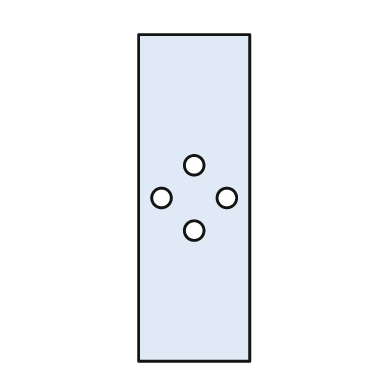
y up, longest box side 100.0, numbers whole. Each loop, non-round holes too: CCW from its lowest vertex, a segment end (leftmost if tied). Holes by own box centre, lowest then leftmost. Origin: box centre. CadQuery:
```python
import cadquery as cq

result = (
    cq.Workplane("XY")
    .moveTo(-17.0, -50.0)
    .lineTo(17.0, -50.0)
    .lineTo(17.0, 50.0)
    .lineTo(-17.0, 50.0)
    .close()
    .moveTo(0.0, -10.0)
    .circle(3.0)
    .moveTo(-10.0, 0.0)
    .circle(3.0)
    .moveTo(10.0, 0.0)
    .circle(3.0)
    .moveTo(0.0, 10.0)
    .circle(3.0)
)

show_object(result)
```